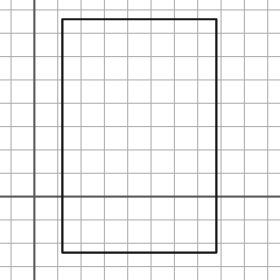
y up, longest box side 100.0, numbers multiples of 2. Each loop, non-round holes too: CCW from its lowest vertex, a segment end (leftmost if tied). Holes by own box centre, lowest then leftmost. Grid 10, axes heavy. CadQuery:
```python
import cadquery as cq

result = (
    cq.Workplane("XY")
    .moveTo(12.0, -24.0)
    .lineTo(78.0, -24.0)
    .lineTo(78.0, 76.0)
    .lineTo(12.0, 76.0)
    .close()
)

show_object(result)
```